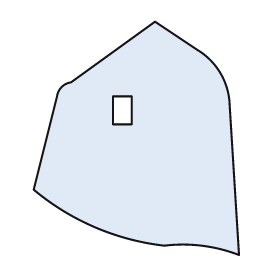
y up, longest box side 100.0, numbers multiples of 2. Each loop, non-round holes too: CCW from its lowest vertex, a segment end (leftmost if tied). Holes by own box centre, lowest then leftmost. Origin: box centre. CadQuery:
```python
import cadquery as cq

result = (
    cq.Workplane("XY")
    .moveTo(44.0, -50.0)
    .lineTo(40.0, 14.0)
    .threePointArc((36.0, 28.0), (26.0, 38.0))
    .lineTo(8.0, 50.0)
    .lineTo(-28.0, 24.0)
    .threePointArc((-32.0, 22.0), (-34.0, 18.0))
    .lineTo(-44.0, -22.0)
    .threePointArc((-18.0, -38.0), (12.0, -46.0))
    .threePointArc((28.0, -46.0), (44.0, -50.0))
    .close()
    .moveTo(-10.0, 6.0)
    .lineTo(-2.0, 6.0)
    .lineTo(-2.0, 18.0)
    .lineTo(-10.0, 18.0)
    .close()
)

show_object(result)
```